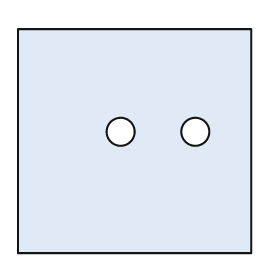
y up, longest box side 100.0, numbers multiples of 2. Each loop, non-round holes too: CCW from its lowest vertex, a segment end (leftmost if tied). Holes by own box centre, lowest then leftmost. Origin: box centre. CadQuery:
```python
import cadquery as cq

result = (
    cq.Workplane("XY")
    .moveTo(-50.0, -48.0)
    .lineTo(50.0, -48.0)
    .lineTo(50.0, 48.0)
    .lineTo(-50.0, 48.0)
    .close()
    .moveTo(-6.0, 4.0)
    .circle(6.0)
    .moveTo(26.0, 4.0)
    .circle(6.0)
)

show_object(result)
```